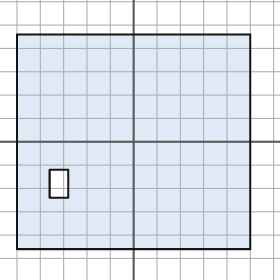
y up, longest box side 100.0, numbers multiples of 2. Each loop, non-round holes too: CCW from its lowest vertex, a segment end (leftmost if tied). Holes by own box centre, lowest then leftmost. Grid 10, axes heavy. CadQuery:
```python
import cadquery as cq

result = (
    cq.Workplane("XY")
    .moveTo(-50.0, -46.0)
    .lineTo(50.0, -46.0)
    .lineTo(50.0, 46.0)
    .lineTo(-50.0, 46.0)
    .close()
    .moveTo(-36.0, -24.0)
    .lineTo(-28.0, -24.0)
    .lineTo(-28.0, -12.0)
    .lineTo(-36.0, -12.0)
    .close()
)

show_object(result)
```